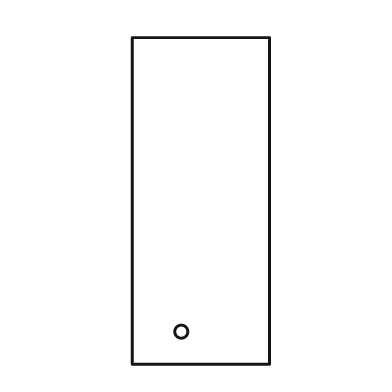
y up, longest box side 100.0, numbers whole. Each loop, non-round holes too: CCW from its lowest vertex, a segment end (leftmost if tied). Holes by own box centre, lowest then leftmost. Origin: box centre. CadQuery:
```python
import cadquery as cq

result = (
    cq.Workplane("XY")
    .moveTo(-21.0, -50.0)
    .lineTo(21.0, -50.0)
    .lineTo(21.0, 50.0)
    .lineTo(-21.0, 50.0)
    .close()
    .moveTo(-6.0, -40.0)
    .circle(2.0)
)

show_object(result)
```